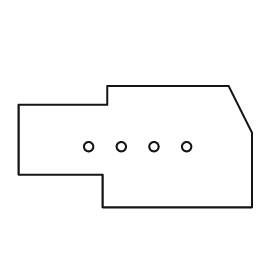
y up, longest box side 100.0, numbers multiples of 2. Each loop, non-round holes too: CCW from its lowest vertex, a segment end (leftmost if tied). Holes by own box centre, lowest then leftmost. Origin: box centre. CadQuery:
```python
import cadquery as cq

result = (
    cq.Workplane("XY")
    .moveTo(-14.0, -26.0)
    .lineTo(50.0, -26.0)
    .lineTo(50.0, 6.0)
    .lineTo(40.0, 26.0)
    .lineTo(-12.0, 26.0)
    .lineTo(-12.0, 18.0)
    .lineTo(-50.0, 18.0)
    .lineTo(-50.0, -12.0)
    .lineTo(-14.0, -12.0)
    .close()
    .moveTo(-20.0, 0.0)
    .circle(2.0)
    .moveTo(-6.0, 0.0)
    .circle(2.0)
    .moveTo(8.0, 0.0)
    .circle(2.0)
    .moveTo(22.0, 0.0)
    .circle(2.0)
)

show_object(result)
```